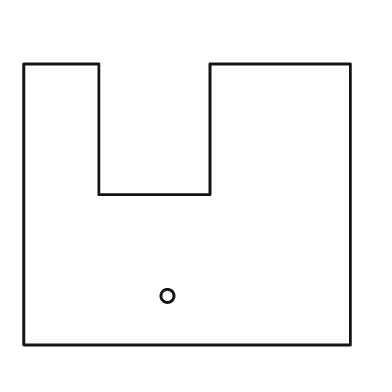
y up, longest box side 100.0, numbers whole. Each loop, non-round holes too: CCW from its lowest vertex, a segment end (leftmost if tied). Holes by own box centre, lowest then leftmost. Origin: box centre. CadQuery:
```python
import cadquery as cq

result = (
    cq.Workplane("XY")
    .moveTo(-50.0, -43.0)
    .lineTo(50.0, -43.0)
    .lineTo(50.0, 43.0)
    .lineTo(7.0, 43.0)
    .lineTo(7.0, 3.0)
    .lineTo(-27.0, 3.0)
    .lineTo(-27.0, 43.0)
    .lineTo(-50.0, 43.0)
    .close()
    .moveTo(-6.0, -28.0)
    .circle(2.0)
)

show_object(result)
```